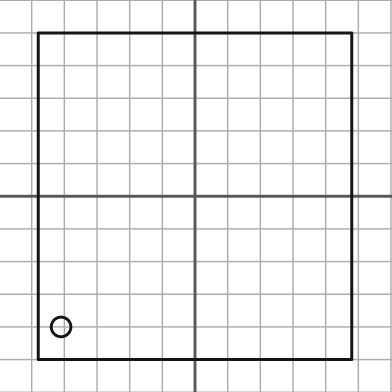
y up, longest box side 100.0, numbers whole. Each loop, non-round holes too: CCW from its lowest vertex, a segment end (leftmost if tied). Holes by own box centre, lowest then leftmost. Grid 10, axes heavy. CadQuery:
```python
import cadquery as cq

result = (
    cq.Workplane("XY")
    .moveTo(-48.0, -50.0)
    .lineTo(48.0, -50.0)
    .lineTo(48.0, 50.0)
    .lineTo(-48.0, 50.0)
    .close()
    .moveTo(-41.0, -40.0)
    .circle(3.0)
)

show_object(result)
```